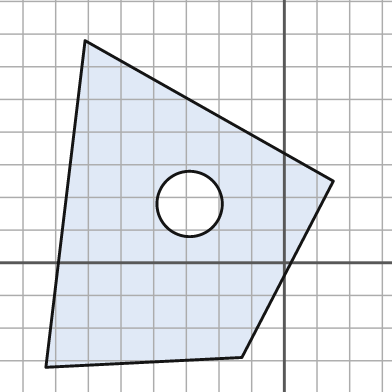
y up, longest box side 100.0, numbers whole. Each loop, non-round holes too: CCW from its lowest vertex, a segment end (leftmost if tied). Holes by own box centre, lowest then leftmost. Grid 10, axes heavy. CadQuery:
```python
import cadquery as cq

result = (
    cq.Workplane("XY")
    .moveTo(-73.0, -32.0)
    .lineTo(-13.0, -29.0)
    .lineTo(15.0, 25.0)
    .lineTo(-61.0, 68.0)
    .close()
    .moveTo(-29.0, 18.0)
    .circle(10.0)
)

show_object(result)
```